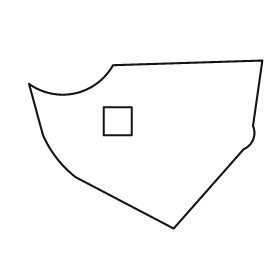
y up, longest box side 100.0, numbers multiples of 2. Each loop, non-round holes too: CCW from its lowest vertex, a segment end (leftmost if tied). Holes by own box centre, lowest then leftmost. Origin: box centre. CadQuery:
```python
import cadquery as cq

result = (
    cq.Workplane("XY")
    .moveTo(12.0, -36.0)
    .lineTo(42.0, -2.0)
    .threePointArc((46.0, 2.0), (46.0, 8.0))
    .lineTo(50.0, 36.0)
    .lineTo(-14.0, 34.0)
    .threePointArc((-30.0, 22.0), (-50.0, 26.0))
    .lineTo(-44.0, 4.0)
    .threePointArc((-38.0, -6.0), (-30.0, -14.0))
    .close()
    .moveTo(-18.0, 4.0)
    .lineTo(-6.0, 4.0)
    .lineTo(-6.0, 16.0)
    .lineTo(-18.0, 16.0)
    .close()
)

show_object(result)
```